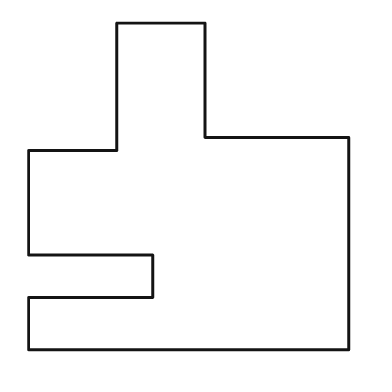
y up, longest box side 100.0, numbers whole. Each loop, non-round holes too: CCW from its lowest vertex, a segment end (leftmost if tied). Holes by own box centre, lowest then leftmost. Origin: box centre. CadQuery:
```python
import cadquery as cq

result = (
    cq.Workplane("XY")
    .moveTo(-49.0, -50.0)
    .lineTo(49.0, -50.0)
    .lineTo(49.0, 15.0)
    .lineTo(5.0, 15.0)
    .lineTo(5.0, 50.0)
    .lineTo(-22.0, 50.0)
    .lineTo(-22.0, 11.0)
    .lineTo(-49.0, 11.0)
    .lineTo(-49.0, -21.0)
    .lineTo(-11.0, -21.0)
    .lineTo(-11.0, -34.0)
    .lineTo(-49.0, -34.0)
    .close()
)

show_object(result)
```